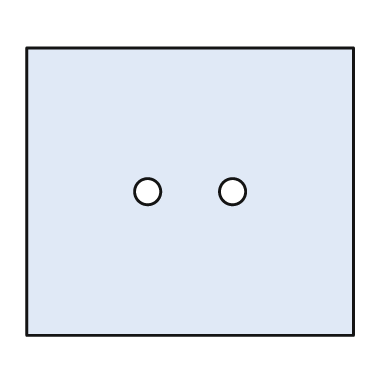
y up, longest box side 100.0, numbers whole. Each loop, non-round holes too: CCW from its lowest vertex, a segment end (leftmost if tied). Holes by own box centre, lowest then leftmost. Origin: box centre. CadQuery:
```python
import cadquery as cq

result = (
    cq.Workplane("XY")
    .moveTo(-50.0, -44.0)
    .lineTo(50.0, -44.0)
    .lineTo(50.0, 44.0)
    .lineTo(-50.0, 44.0)
    .close()
    .moveTo(-13.0, 0.0)
    .circle(4.0)
    .moveTo(13.0, 0.0)
    .circle(4.0)
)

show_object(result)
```